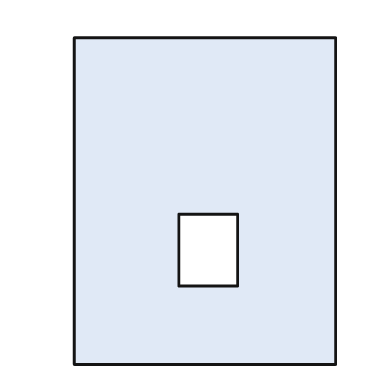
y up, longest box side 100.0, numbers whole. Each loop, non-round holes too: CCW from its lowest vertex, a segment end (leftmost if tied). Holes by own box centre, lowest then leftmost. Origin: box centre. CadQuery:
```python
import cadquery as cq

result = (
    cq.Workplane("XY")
    .moveTo(-40.0, -50.0)
    .lineTo(40.0, -50.0)
    .lineTo(40.0, 50.0)
    .lineTo(-40.0, 50.0)
    .close()
    .moveTo(-8.0, -26.0)
    .lineTo(10.0, -26.0)
    .lineTo(10.0, -4.0)
    .lineTo(-8.0, -4.0)
    .close()
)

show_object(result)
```